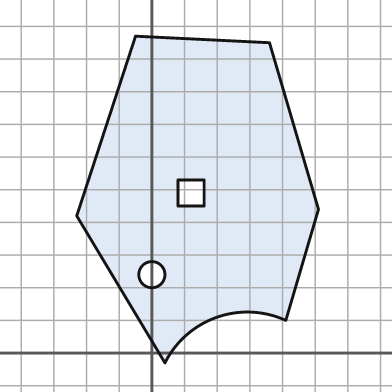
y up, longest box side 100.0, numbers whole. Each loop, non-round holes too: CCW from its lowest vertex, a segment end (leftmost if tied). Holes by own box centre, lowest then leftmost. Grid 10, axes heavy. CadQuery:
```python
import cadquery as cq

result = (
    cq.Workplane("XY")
    .moveTo(4.0, -3.0)
    .threePointArc((20.0, 11.0), (41.0, 10.0))
    .lineTo(51.0, 44.0)
    .lineTo(36.0, 95.0)
    .lineTo(-5.0, 97.0)
    .lineTo(-23.0, 42.0)
    .close()
    .moveTo(0.0, 24.0)
    .circle(4.0)
    .moveTo(8.0, 45.0)
    .lineTo(16.0, 45.0)
    .lineTo(16.0, 53.0)
    .lineTo(8.0, 53.0)
    .close()
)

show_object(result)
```